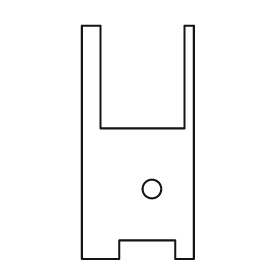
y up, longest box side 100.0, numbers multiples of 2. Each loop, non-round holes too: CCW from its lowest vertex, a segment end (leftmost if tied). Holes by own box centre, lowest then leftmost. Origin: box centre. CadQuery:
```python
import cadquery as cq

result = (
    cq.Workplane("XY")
    .moveTo(-24.0, -50.0)
    .lineTo(-8.0, -50.0)
    .lineTo(-8.0, -42.0)
    .lineTo(16.0, -42.0)
    .lineTo(16.0, -50.0)
    .lineTo(24.0, -50.0)
    .lineTo(24.0, 50.0)
    .lineTo(20.0, 50.0)
    .lineTo(20.0, 6.0)
    .lineTo(-16.0, 6.0)
    .lineTo(-16.0, 50.0)
    .lineTo(-24.0, 50.0)
    .close()
    .moveTo(6.0, -20.0)
    .circle(4.0)
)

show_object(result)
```